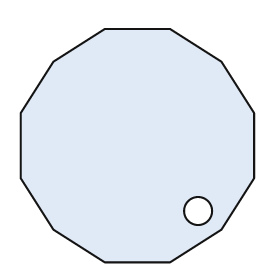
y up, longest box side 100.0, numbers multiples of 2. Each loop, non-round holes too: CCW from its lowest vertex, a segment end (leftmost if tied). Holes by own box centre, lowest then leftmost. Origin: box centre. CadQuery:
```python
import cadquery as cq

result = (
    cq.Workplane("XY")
    .moveTo(-14.0, -50.0)
    .lineTo(14.0, -50.0)
    .lineTo(36.0, -36.0)
    .lineTo(50.0, -14.0)
    .lineTo(50.0, 14.0)
    .lineTo(36.0, 36.0)
    .lineTo(14.0, 50.0)
    .lineTo(-14.0, 50.0)
    .lineTo(-36.0, 36.0)
    .lineTo(-50.0, 14.0)
    .lineTo(-50.0, -14.0)
    .lineTo(-36.0, -36.0)
    .close()
    .moveTo(26.0, -28.0)
    .circle(6.0)
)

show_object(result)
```